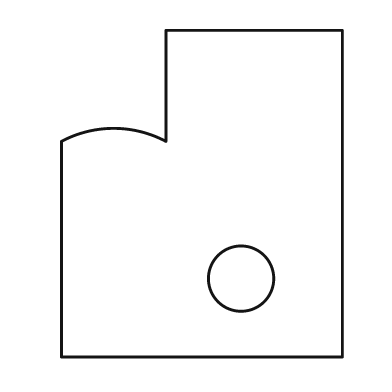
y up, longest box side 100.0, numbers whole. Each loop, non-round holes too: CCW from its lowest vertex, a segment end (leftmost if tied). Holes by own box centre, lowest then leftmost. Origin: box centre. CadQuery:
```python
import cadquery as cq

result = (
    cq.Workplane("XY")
    .moveTo(-43.0, -50.0)
    .lineTo(43.0, -50.0)
    .lineTo(43.0, 50.0)
    .lineTo(-11.0, 50.0)
    .lineTo(-11.0, 16.0)
    .threePointArc((-27.0, 20.0), (-43.0, 16.0))
    .close()
    .moveTo(12.0, -26.0)
    .circle(10.0)
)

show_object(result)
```